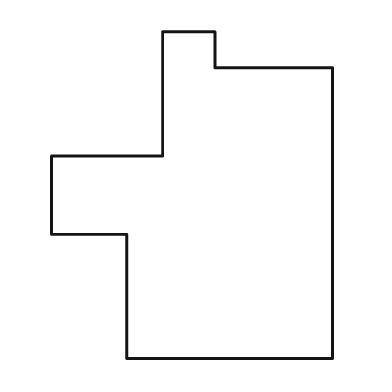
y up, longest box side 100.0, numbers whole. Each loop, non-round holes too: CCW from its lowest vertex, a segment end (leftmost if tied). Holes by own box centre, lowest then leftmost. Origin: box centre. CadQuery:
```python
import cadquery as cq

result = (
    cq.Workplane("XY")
    .moveTo(-20.0, -50.0)
    .lineTo(43.0, -50.0)
    .lineTo(43.0, 39.0)
    .lineTo(7.0, 39.0)
    .lineTo(7.0, 50.0)
    .lineTo(-9.0, 50.0)
    .lineTo(-9.0, 12.0)
    .lineTo(-43.0, 12.0)
    .lineTo(-43.0, -12.0)
    .lineTo(-20.0, -12.0)
    .close()
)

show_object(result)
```